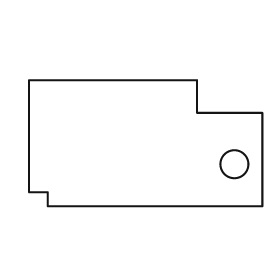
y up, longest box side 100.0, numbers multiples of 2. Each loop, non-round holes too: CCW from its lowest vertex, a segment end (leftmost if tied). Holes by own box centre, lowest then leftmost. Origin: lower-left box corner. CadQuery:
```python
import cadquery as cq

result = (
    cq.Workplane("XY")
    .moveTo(8.0, 0.0)
    .lineTo(100.0, 0.0)
    .lineTo(100.0, 40.0)
    .lineTo(72.0, 40.0)
    .lineTo(72.0, 54.0)
    .lineTo(0.0, 54.0)
    .lineTo(0.0, 6.0)
    .lineTo(8.0, 6.0)
    .close()
    .moveTo(88.0, 18.0)
    .circle(6.0)
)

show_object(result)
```